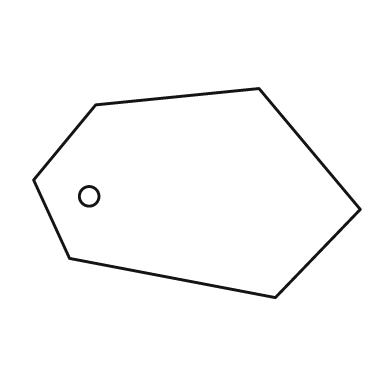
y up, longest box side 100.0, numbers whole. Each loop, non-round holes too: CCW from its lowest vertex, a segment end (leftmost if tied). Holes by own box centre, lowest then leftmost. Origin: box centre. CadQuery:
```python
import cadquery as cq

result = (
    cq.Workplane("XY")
    .moveTo(24.0, -32.0)
    .lineTo(50.0, -5.0)
    .lineTo(19.0, 32.0)
    .lineTo(-31.0, 27.0)
    .lineTo(-50.0, 4.0)
    .lineTo(-39.0, -20.0)
    .close()
    .moveTo(-33.0, -1.0)
    .circle(3.0)
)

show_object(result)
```